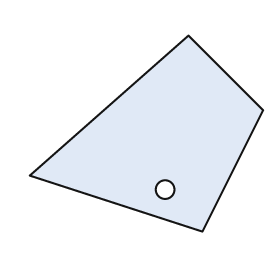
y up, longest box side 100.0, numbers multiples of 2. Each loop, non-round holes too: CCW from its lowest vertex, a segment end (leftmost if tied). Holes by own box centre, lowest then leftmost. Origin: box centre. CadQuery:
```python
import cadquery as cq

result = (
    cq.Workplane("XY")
    .moveTo(24.0, -42.0)
    .lineTo(50.0, 10.0)
    .lineTo(18.0, 42.0)
    .lineTo(-50.0, -18.0)
    .close()
    .moveTo(8.0, -24.0)
    .circle(4.0)
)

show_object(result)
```